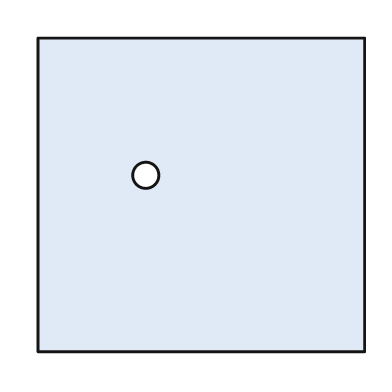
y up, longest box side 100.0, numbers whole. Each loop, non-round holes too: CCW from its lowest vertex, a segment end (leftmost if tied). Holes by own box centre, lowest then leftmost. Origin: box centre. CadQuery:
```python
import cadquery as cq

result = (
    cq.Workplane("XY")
    .moveTo(-50.0, -48.0)
    .lineTo(50.0, -48.0)
    .lineTo(50.0, 48.0)
    .lineTo(-50.0, 48.0)
    .close()
    .moveTo(-17.0, 6.0)
    .circle(4.0)
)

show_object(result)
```